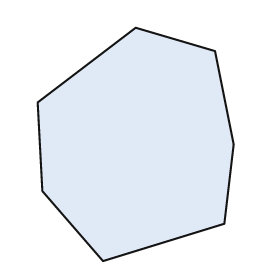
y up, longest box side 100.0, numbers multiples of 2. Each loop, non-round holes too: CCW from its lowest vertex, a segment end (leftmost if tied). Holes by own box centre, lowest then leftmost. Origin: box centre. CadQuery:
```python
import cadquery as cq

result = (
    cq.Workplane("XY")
    .moveTo(-14.0, -50.0)
    .lineTo(38.0, -34.0)
    .lineTo(42.0, 0.0)
    .lineTo(34.0, 40.0)
    .lineTo(0.0, 50.0)
    .lineTo(-42.0, 18.0)
    .lineTo(-40.0, -20.0)
    .close()
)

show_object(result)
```